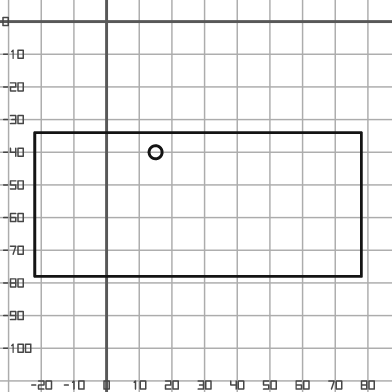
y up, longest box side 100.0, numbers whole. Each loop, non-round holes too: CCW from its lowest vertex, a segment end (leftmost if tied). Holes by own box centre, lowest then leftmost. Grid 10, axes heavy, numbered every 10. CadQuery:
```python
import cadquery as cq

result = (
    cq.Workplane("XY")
    .moveTo(-22.0, -78.0)
    .lineTo(78.0, -78.0)
    .lineTo(78.0, -34.0)
    .lineTo(-22.0, -34.0)
    .close()
    .moveTo(15.0, -40.0)
    .circle(2.0)
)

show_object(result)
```